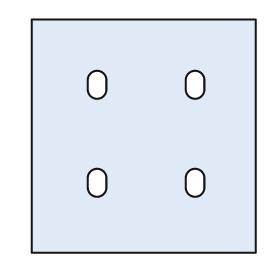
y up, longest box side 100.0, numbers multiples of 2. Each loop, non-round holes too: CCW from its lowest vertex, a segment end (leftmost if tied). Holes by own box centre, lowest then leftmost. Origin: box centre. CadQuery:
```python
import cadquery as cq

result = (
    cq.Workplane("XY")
    .moveTo(-48.0, -50.0)
    .lineTo(48.0, -50.0)
    .lineTo(48.0, 50.0)
    .lineTo(-48.0, 50.0)
    .close()
    .moveTo(-24.0, -22.0)
    .threePointArc((-20.0, -26.0), (-16.0, -22.0))
    .lineTo(-16.0, -18.0)
    .threePointArc((-20.0, -14.0), (-24.0, -18.0))
    .close()
    .moveTo(18.0, -22.0)
    .threePointArc((22.0, -26.0), (26.0, -22.0))
    .lineTo(26.0, -18.0)
    .threePointArc((22.0, -14.0), (18.0, -18.0))
    .close()
    .moveTo(-24.0, 20.0)
    .threePointArc((-20.0, 16.0), (-16.0, 20.0))
    .lineTo(-16.0, 24.0)
    .threePointArc((-20.0, 28.0), (-24.0, 24.0))
    .close()
    .moveTo(18.0, 20.0)
    .threePointArc((22.0, 16.0), (26.0, 20.0))
    .lineTo(26.0, 24.0)
    .threePointArc((22.0, 28.0), (18.0, 24.0))
    .close()
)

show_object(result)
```